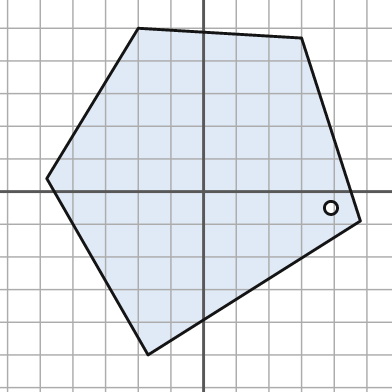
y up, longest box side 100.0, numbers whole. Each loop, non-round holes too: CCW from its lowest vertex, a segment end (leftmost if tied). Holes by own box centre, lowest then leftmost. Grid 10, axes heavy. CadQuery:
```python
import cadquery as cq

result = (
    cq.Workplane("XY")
    .moveTo(-17.0, -50.0)
    .lineTo(48.0, -9.0)
    .lineTo(30.0, 47.0)
    .lineTo(-20.0, 50.0)
    .lineTo(-48.0, 4.0)
    .close()
    .moveTo(39.0, -5.0)
    .circle(2.0)
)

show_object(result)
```